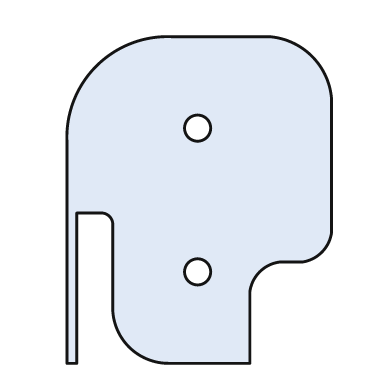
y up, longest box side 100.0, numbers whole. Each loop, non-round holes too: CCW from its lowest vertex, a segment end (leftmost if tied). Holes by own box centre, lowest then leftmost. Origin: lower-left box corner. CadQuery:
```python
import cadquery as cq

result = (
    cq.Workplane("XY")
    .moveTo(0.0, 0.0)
    .lineTo(3.0, 0.0)
    .lineTo(3.0, 46.0)
    .lineTo(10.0, 46.0)
    .threePointArc((13.0, 45.0), (14.0, 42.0))
    .lineTo(14.0, 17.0)
    .threePointArc((19.0, 5.0), (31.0, 0.0))
    .lineTo(56.0, 0.0)
    .lineTo(56.0, 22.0)
    .threePointArc((59.0, 28.0), (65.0, 31.0))
    .lineTo(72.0, 31.0)
    .threePointArc((78.0, 34.0), (81.0, 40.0))
    .lineTo(81.0, 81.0)
    .threePointArc((75.0, 94.0), (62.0, 100.0))
    .lineTo(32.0, 100.0)
    .threePointArc((9.0, 91.0), (0.0, 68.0))
    .close()
    .moveTo(40.0, 28.0)
    .circle(4.0)
    .moveTo(40.0, 72.0)
    .circle(4.0)
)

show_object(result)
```